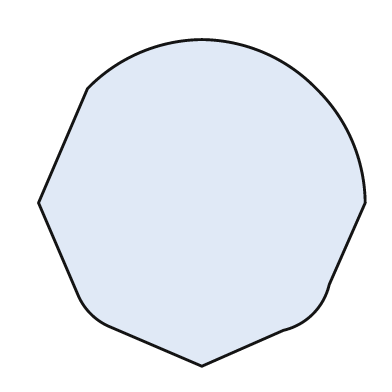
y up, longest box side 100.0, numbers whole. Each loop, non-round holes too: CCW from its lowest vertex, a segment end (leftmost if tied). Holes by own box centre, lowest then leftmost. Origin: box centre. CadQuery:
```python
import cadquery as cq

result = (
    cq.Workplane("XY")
    .moveTo(0.0, -50.0)
    .lineTo(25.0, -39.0)
    .threePointArc((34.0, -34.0), (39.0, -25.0))
    .lineTo(50.0, 0.0)
    .threePointArc((46.0, 19.0), (35.0, 35.0))
    .threePointArc((19.0, 46.0), (0.0, 50.0))
    .threePointArc((-19.0, 46.0), (-35.0, 35.0))
    .lineTo(-50.0, 0.0)
    .lineTo(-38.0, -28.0)
    .threePointArc((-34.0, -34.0), (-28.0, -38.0))
    .close()
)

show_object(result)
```